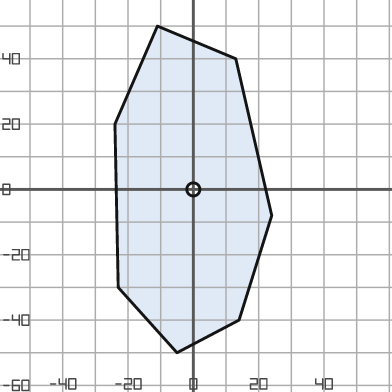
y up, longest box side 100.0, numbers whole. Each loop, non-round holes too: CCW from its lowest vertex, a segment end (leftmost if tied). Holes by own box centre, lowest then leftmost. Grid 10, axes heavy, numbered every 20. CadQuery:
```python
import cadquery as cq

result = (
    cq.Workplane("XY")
    .moveTo(-5.0, -50.0)
    .lineTo(14.0, -40.0)
    .lineTo(24.0, -8.0)
    .lineTo(13.0, 40.0)
    .lineTo(-11.0, 50.0)
    .lineTo(-24.0, 20.0)
    .lineTo(-23.0, -30.0)
    .close()
    .moveTo(0.0, 0.0)
    .circle(2.0)
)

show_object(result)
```